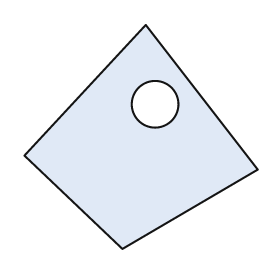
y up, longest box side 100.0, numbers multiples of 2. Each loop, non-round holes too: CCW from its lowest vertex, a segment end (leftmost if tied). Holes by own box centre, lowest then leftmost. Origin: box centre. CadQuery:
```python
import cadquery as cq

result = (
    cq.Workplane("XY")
    .moveTo(-8.0, -48.0)
    .lineTo(50.0, -14.0)
    .lineTo(2.0, 48.0)
    .lineTo(-50.0, -8.0)
    .close()
    .moveTo(6.0, 14.0)
    .circle(10.0)
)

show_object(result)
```